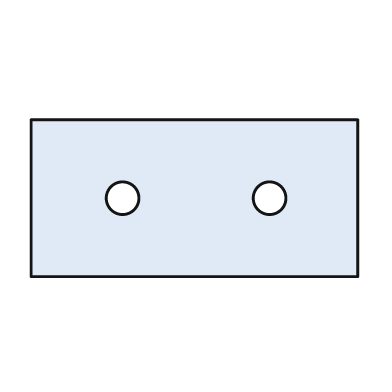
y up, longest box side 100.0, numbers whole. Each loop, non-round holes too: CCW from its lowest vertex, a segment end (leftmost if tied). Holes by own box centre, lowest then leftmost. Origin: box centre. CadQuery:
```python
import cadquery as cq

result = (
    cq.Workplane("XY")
    .moveTo(-50.0, -24.0)
    .lineTo(50.0, -24.0)
    .lineTo(50.0, 24.0)
    .lineTo(-50.0, 24.0)
    .close()
    .moveTo(-22.0, 0.0)
    .circle(5.0)
    .moveTo(23.0, 0.0)
    .circle(5.0)
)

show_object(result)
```